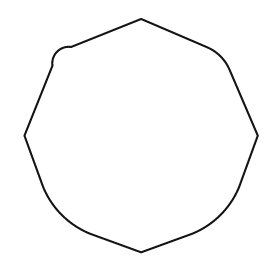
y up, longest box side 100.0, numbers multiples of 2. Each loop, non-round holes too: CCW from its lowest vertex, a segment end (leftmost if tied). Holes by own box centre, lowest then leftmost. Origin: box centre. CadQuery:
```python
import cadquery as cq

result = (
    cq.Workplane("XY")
    .moveTo(0.0, -50.0)
    .lineTo(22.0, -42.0)
    .threePointArc((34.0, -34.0), (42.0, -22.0))
    .lineTo(50.0, 0.0)
    .lineTo(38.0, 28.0)
    .threePointArc((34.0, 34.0), (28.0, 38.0))
    .lineTo(0.0, 50.0)
    .lineTo(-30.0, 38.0)
    .threePointArc((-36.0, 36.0), (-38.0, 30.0))
    .lineTo(-50.0, 0.0)
    .lineTo(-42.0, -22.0)
    .threePointArc((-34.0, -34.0), (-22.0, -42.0))
    .close()
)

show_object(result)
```